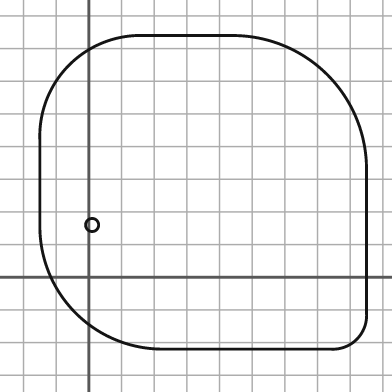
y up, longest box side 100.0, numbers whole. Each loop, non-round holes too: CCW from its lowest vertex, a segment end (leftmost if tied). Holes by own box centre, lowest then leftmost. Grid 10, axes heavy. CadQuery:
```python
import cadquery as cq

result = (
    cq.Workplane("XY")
    .moveTo(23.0, -22.0)
    .lineTo(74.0, -22.0)
    .threePointArc((82.0, -19.0), (85.0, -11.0))
    .lineTo(85.0, 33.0)
    .threePointArc((73.0, 62.0), (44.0, 74.0))
    .lineTo(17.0, 74.0)
    .threePointArc((-6.0, 65.0), (-15.0, 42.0))
    .lineTo(-15.0, 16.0)
    .threePointArc((-4.0, -11.0), (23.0, -22.0))
    .close()
    .moveTo(1.0, 16.0)
    .circle(2.0)
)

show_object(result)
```